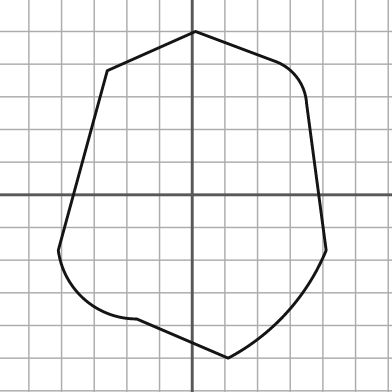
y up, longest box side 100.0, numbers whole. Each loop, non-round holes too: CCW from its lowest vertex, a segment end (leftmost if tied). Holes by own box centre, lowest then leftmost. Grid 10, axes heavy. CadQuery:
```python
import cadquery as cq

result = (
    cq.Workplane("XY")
    .moveTo(11.0, -50.0)
    .threePointArc((29.0, -36.0), (41.0, -17.0))
    .lineTo(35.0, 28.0)
    .threePointArc((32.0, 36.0), (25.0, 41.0))
    .lineTo(1.0, 50.0)
    .lineTo(-26.0, 38.0)
    .lineTo(-41.0, -17.0)
    .threePointArc((-33.0, -32.0), (-17.0, -38.0))
    .close()
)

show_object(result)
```